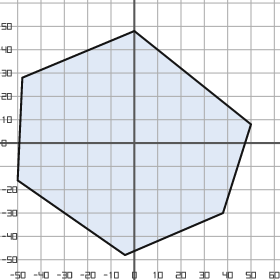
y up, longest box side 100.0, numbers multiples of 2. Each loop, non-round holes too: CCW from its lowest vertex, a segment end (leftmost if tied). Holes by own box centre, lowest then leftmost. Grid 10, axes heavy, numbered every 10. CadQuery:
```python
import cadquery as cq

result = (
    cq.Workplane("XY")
    .moveTo(-4.0, -48.0)
    .lineTo(38.0, -30.0)
    .lineTo(50.0, 8.0)
    .lineTo(0.0, 48.0)
    .lineTo(-48.0, 28.0)
    .lineTo(-50.0, -16.0)
    .close()
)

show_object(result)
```